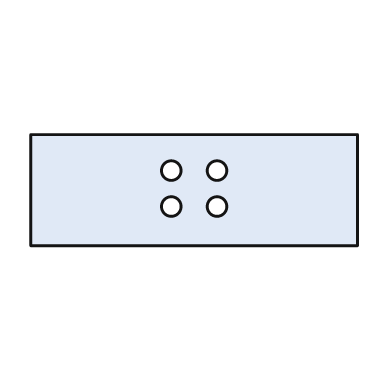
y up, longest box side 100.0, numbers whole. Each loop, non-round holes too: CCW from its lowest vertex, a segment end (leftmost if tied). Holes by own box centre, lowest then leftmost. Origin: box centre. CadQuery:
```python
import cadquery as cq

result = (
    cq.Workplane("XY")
    .moveTo(-50.0, -17.0)
    .lineTo(50.0, -17.0)
    .lineTo(50.0, 17.0)
    .lineTo(-50.0, 17.0)
    .close()
    .moveTo(-7.0, -5.0)
    .circle(3.0)
    .moveTo(7.0, -5.0)
    .circle(3.0)
    .moveTo(-7.0, 6.0)
    .circle(3.0)
    .moveTo(7.0, 6.0)
    .circle(3.0)
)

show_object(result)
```